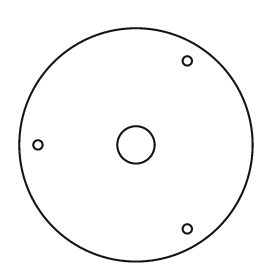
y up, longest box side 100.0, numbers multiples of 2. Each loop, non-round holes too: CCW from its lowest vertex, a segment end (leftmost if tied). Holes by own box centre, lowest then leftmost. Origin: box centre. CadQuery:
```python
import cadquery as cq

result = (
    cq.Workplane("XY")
    .moveTo(0.0, 0.0)
    .circle(50.0)
    .moveTo(22.0, -36.0)
    .circle(2.0)
    .moveTo(-42.0, 0.0)
    .circle(2.0)
    .moveTo(0.0, 0.0)
    .circle(8.0)
    .moveTo(22.0, 36.0)
    .circle(2.0)
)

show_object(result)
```